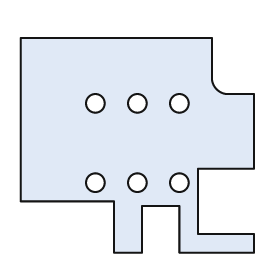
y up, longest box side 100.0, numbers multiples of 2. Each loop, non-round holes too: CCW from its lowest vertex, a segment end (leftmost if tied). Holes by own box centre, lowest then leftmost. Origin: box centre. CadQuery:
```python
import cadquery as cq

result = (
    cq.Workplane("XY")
    .moveTo(-10.0, -46.0)
    .lineTo(2.0, -46.0)
    .lineTo(2.0, -26.0)
    .lineTo(18.0, -26.0)
    .lineTo(18.0, -46.0)
    .lineTo(50.0, -46.0)
    .lineTo(50.0, -38.0)
    .lineTo(26.0, -38.0)
    .lineTo(26.0, -10.0)
    .lineTo(50.0, -10.0)
    .lineTo(50.0, 22.0)
    .lineTo(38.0, 22.0)
    .threePointArc((34.0, 24.0), (32.0, 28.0))
    .lineTo(32.0, 46.0)
    .lineTo(-50.0, 46.0)
    .lineTo(-50.0, -24.0)
    .lineTo(-10.0, -24.0)
    .close()
    .moveTo(-18.0, -16.0)
    .circle(4.0)
    .moveTo(0.0, -16.0)
    .circle(4.0)
    .moveTo(18.0, -16.0)
    .circle(4.0)
    .moveTo(-18.0, 18.0)
    .circle(4.0)
    .moveTo(0.0, 18.0)
    .circle(4.0)
    .moveTo(18.0, 18.0)
    .circle(4.0)
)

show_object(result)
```